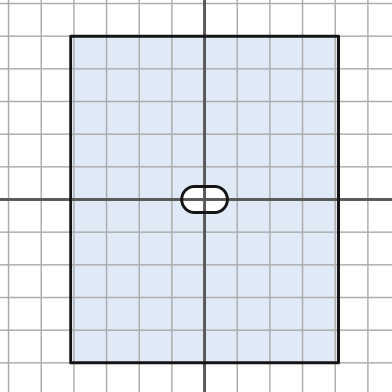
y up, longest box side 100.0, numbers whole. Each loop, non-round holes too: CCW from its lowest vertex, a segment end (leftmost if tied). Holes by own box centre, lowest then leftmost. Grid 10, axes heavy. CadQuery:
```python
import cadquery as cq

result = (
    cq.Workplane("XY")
    .moveTo(-41.0, -50.0)
    .lineTo(41.0, -50.0)
    .lineTo(41.0, 50.0)
    .lineTo(-41.0, 50.0)
    .close()
    .moveTo(-3.0, -4.0)
    .lineTo(3.0, -4.0)
    .threePointArc((7.0, 0.0), (3.0, 4.0))
    .lineTo(-3.0, 4.0)
    .threePointArc((-7.0, 0.0), (-3.0, -4.0))
    .close()
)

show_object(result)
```